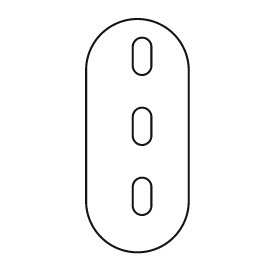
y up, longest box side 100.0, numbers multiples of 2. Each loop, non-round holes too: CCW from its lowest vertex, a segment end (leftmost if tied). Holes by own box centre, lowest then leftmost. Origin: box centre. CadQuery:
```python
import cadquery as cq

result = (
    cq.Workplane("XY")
    .moveTo(-22.0, -28.0)
    .threePointArc((0.0, -50.0), (22.0, -28.0))
    .lineTo(22.0, 28.0)
    .threePointArc((0.0, 50.0), (-22.0, 28.0))
    .close()
    .moveTo(-2.0, -30.0)
    .threePointArc((2.0, -34.0), (6.0, -30.0))
    .lineTo(6.0, -22.0)
    .threePointArc((2.0, -18.0), (-2.0, -22.0))
    .close()
    .moveTo(-2.0, 0.0)
    .threePointArc((2.0, -4.0), (6.0, 0.0))
    .lineTo(6.0, 8.0)
    .threePointArc((2.0, 12.0), (-2.0, 8.0))
    .close()
    .moveTo(-2.0, 30.0)
    .threePointArc((2.0, 26.0), (6.0, 30.0))
    .lineTo(6.0, 38.0)
    .threePointArc((2.0, 42.0), (-2.0, 38.0))
    .close()
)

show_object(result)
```